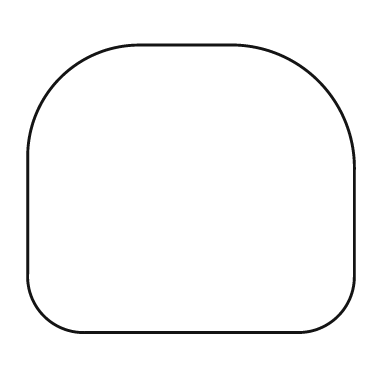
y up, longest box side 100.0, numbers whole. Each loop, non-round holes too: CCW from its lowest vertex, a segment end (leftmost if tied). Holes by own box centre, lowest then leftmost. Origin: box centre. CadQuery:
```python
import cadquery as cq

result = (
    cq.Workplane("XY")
    .moveTo(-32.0, -44.0)
    .lineTo(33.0, -44.0)
    .threePointArc((45.0, -39.0), (50.0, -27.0))
    .lineTo(50.0, 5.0)
    .threePointArc((39.0, 33.0), (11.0, 44.0))
    .lineTo(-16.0, 44.0)
    .threePointArc((-40.0, 34.0), (-50.0, 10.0))
    .lineTo(-50.0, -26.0)
    .threePointArc((-45.0, -39.0), (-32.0, -44.0))
    .close()
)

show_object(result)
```